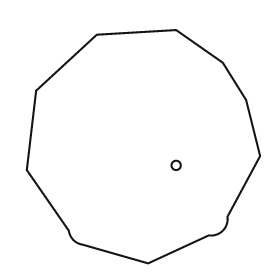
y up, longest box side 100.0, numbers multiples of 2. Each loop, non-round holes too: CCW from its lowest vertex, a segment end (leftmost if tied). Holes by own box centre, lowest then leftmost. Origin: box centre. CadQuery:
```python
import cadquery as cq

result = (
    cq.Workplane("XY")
    .moveTo(2.0, -50.0)
    .lineTo(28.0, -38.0)
    .threePointArc((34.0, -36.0), (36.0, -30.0))
    .lineTo(50.0, -4.0)
    .lineTo(44.0, 20.0)
    .lineTo(34.0, 36.0)
    .lineTo(14.0, 50.0)
    .lineTo(-20.0, 48.0)
    .lineTo(-46.0, 24.0)
    .lineTo(-50.0, -10.0)
    .lineTo(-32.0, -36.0)
    .threePointArc((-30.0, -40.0), (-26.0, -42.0))
    .close()
    .moveTo(14.0, -8.0)
    .circle(2.0)
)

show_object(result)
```